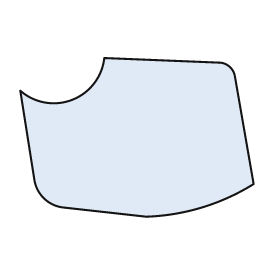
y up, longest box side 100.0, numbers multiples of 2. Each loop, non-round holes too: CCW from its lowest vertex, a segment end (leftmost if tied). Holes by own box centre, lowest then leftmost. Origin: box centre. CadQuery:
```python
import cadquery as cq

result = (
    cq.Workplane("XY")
    .moveTo(4.0, -34.0)
    .threePointArc((28.0, -30.0), (50.0, -20.0))
    .lineTo(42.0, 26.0)
    .threePointArc((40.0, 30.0), (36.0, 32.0))
    .lineTo(-14.0, 34.0)
    .threePointArc((-28.0, 16.0), (-50.0, 20.0))
    .lineTo(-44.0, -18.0)
    .threePointArc((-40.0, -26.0), (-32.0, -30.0))
    .close()
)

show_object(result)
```